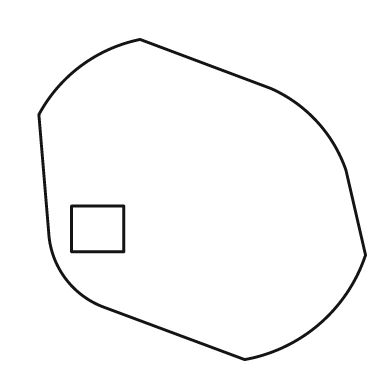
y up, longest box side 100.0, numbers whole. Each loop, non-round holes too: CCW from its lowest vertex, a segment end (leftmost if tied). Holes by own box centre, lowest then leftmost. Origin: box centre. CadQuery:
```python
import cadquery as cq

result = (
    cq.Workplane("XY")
    .moveTo(13.0, -49.0)
    .threePointArc((36.0, -38.0), (50.0, -17.0))
    .lineTo(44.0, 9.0)
    .threePointArc((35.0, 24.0), (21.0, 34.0))
    .lineTo(-19.0, 49.0)
    .threePointArc((-37.0, 41.0), (-50.0, 26.0))
    .lineTo(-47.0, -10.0)
    .threePointArc((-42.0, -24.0), (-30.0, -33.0))
    .close()
    .moveTo(-40.0, -16.0)
    .lineTo(-24.0, -16.0)
    .lineTo(-24.0, -2.0)
    .lineTo(-40.0, -2.0)
    .close()
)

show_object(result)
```